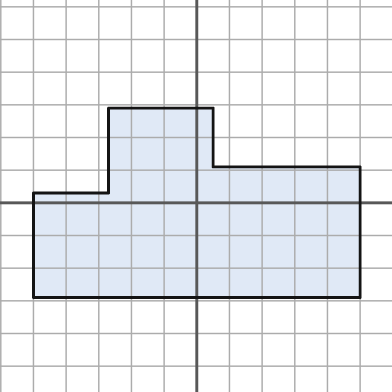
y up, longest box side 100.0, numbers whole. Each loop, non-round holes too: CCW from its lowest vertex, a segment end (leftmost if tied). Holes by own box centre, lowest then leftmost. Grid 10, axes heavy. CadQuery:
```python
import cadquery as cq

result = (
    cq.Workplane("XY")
    .moveTo(-50.0, -29.0)
    .lineTo(50.0, -29.0)
    .lineTo(50.0, 11.0)
    .lineTo(5.0, 11.0)
    .lineTo(5.0, 29.0)
    .lineTo(-27.0, 29.0)
    .lineTo(-27.0, 3.0)
    .lineTo(-50.0, 3.0)
    .close()
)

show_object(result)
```